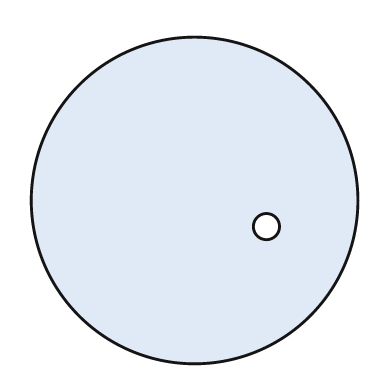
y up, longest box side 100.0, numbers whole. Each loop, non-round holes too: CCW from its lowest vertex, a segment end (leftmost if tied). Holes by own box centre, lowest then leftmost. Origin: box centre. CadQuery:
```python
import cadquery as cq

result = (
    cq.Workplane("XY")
    .moveTo(0.0, 0.0)
    .circle(50.0)
    .moveTo(22.0, -8.0)
    .circle(4.0)
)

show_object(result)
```